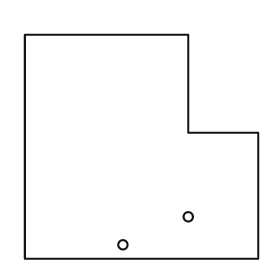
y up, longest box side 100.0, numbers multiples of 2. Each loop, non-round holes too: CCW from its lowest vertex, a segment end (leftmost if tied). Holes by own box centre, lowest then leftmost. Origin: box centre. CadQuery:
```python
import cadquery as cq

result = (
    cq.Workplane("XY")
    .moveTo(-50.0, -48.0)
    .lineTo(50.0, -48.0)
    .lineTo(50.0, 6.0)
    .lineTo(20.0, 6.0)
    .lineTo(20.0, 48.0)
    .lineTo(-50.0, 48.0)
    .close()
    .moveTo(-8.0, -42.0)
    .circle(2.0)
    .moveTo(20.0, -30.0)
    .circle(2.0)
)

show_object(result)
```